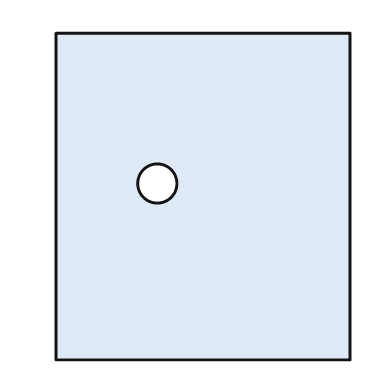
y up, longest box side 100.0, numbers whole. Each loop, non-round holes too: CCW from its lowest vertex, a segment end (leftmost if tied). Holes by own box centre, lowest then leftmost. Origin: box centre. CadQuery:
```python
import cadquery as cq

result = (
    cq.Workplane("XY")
    .moveTo(-45.0, -50.0)
    .lineTo(45.0, -50.0)
    .lineTo(45.0, 50.0)
    .lineTo(-45.0, 50.0)
    .close()
    .moveTo(-14.0, 4.0)
    .circle(6.0)
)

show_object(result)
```